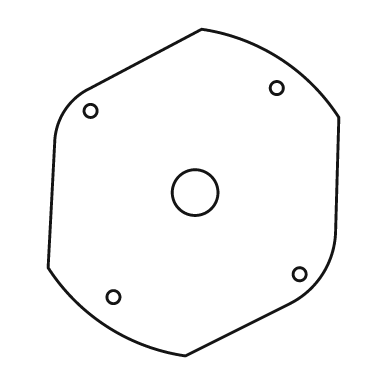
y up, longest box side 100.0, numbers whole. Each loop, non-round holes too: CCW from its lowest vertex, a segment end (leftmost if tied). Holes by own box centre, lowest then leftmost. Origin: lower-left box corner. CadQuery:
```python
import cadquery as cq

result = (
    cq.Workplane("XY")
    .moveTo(42.0, 0.0)
    .lineTo(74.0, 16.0)
    .threePointArc((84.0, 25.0), (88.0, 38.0))
    .lineTo(89.0, 73.0)
    .threePointArc((71.0, 91.0), (47.0, 100.0))
    .lineTo(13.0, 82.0)
    .threePointArc((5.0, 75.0), (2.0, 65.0))
    .lineTo(0.0, 27.0)
    .threePointArc((18.0, 9.0), (42.0, 0.0))
    .close()
    .moveTo(20.0, 18.0)
    .circle(2.0)
    .moveTo(77.0, 25.0)
    .circle(2.0)
    .moveTo(45.0, 50.0)
    .circle(7.0)
    .moveTo(13.0, 75.0)
    .circle(2.0)
    .moveTo(70.0, 82.0)
    .circle(2.0)
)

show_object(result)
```